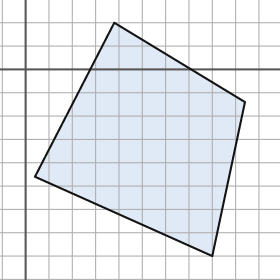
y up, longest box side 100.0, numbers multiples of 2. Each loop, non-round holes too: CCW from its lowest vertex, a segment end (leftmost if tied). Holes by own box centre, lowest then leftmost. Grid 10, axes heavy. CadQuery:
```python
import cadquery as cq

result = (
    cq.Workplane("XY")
    .moveTo(80.0, -80.0)
    .lineTo(94.0, -14.0)
    .lineTo(38.0, 20.0)
    .lineTo(4.0, -46.0)
    .close()
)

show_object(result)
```